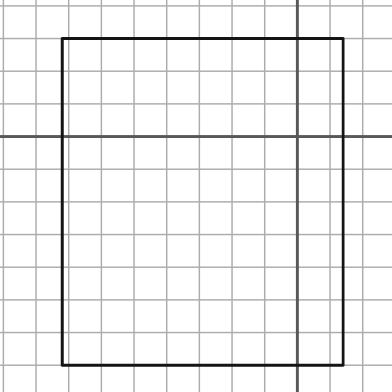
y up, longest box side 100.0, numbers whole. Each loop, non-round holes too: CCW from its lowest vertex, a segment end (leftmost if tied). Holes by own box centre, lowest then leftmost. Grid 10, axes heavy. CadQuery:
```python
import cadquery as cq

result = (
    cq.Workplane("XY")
    .moveTo(-72.0, -70.0)
    .lineTo(14.0, -70.0)
    .lineTo(14.0, 30.0)
    .lineTo(-72.0, 30.0)
    .close()
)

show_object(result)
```